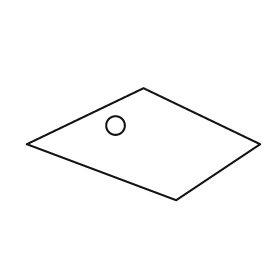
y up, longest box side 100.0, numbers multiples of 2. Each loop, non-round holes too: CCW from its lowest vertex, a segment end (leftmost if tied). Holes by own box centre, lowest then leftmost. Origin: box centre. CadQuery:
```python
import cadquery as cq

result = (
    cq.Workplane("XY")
    .moveTo(14.0, -24.0)
    .lineTo(50.0, 0.0)
    .lineTo(0.0, 24.0)
    .lineTo(-50.0, 0.0)
    .close()
    .moveTo(-12.0, 8.0)
    .circle(4.0)
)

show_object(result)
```